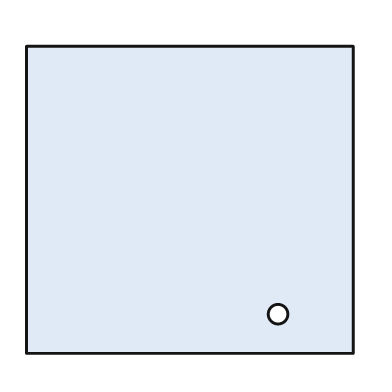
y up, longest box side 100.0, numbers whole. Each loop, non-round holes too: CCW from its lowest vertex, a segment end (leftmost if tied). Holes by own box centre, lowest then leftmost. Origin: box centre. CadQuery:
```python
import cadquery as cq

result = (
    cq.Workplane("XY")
    .moveTo(-50.0, -47.0)
    .lineTo(50.0, -47.0)
    .lineTo(50.0, 47.0)
    .lineTo(-50.0, 47.0)
    .close()
    .moveTo(27.0, -35.0)
    .circle(3.0)
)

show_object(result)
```